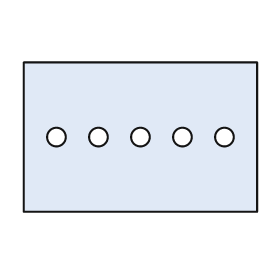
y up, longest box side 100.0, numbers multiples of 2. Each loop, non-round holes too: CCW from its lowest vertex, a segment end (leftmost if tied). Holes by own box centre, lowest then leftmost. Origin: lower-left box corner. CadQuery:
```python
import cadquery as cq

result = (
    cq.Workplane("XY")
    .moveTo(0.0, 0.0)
    .lineTo(100.0, 0.0)
    .lineTo(100.0, 64.0)
    .lineTo(0.0, 64.0)
    .close()
    .moveTo(14.0, 32.0)
    .circle(4.0)
    .moveTo(32.0, 32.0)
    .circle(4.0)
    .moveTo(50.0, 32.0)
    .circle(4.0)
    .moveTo(68.0, 32.0)
    .circle(4.0)
    .moveTo(86.0, 32.0)
    .circle(4.0)
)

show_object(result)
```